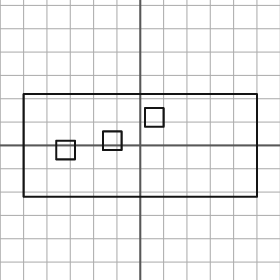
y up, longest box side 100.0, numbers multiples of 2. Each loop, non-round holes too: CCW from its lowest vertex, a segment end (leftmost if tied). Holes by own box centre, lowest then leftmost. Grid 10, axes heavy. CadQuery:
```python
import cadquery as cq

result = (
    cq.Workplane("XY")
    .moveTo(-50.0, -22.0)
    .lineTo(50.0, -22.0)
    .lineTo(50.0, 22.0)
    .lineTo(-50.0, 22.0)
    .close()
    .moveTo(-36.0, -6.0)
    .lineTo(-28.0, -6.0)
    .lineTo(-28.0, 2.0)
    .lineTo(-36.0, 2.0)
    .close()
    .moveTo(-16.0, -2.0)
    .lineTo(-8.0, -2.0)
    .lineTo(-8.0, 6.0)
    .lineTo(-16.0, 6.0)
    .close()
    .moveTo(2.0, 8.0)
    .lineTo(10.0, 8.0)
    .lineTo(10.0, 16.0)
    .lineTo(2.0, 16.0)
    .close()
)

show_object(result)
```